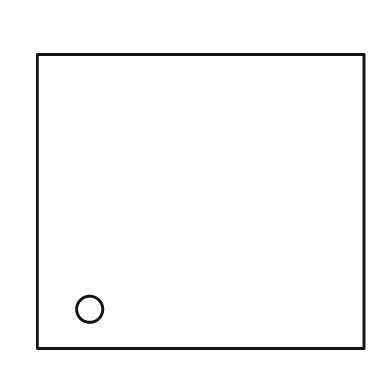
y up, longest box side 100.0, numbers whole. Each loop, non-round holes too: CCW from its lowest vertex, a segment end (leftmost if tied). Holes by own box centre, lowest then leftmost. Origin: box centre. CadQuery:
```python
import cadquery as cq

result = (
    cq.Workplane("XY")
    .moveTo(-50.0, -45.0)
    .lineTo(50.0, -45.0)
    .lineTo(50.0, 45.0)
    .lineTo(-50.0, 45.0)
    .close()
    .moveTo(-34.0, -33.0)
    .circle(4.0)
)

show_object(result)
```